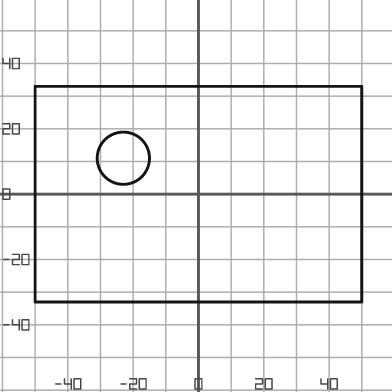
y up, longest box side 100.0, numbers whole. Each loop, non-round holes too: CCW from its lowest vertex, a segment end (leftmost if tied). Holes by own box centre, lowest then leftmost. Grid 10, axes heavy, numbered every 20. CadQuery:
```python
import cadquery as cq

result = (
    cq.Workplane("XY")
    .moveTo(-50.0, -33.0)
    .lineTo(50.0, -33.0)
    .lineTo(50.0, 33.0)
    .lineTo(-50.0, 33.0)
    .close()
    .moveTo(-23.0, 11.0)
    .circle(8.0)
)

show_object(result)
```